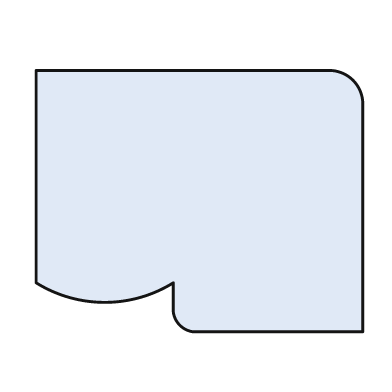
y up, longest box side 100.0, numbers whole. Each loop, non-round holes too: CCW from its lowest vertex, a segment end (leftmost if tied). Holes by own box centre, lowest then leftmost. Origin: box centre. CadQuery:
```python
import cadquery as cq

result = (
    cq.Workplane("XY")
    .moveTo(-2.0, -40.0)
    .lineTo(50.0, -40.0)
    .lineTo(50.0, 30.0)
    .threePointArc((47.0, 37.0), (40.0, 40.0))
    .lineTo(-50.0, 40.0)
    .lineTo(-50.0, -25.0)
    .threePointArc((-29.0, -31.0), (-8.0, -25.0))
    .lineTo(-8.0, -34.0)
    .threePointArc((-6.0, -38.0), (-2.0, -40.0))
    .close()
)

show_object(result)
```